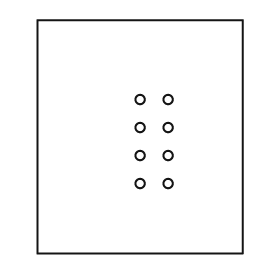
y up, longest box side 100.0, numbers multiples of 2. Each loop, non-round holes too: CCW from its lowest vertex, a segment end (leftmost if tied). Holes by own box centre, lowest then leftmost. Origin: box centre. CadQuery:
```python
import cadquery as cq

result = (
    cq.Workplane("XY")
    .moveTo(-44.0, -50.0)
    .lineTo(44.0, -50.0)
    .lineTo(44.0, 50.0)
    .lineTo(-44.0, 50.0)
    .close()
    .moveTo(0.0, -20.0)
    .circle(2.0)
    .moveTo(12.0, -20.0)
    .circle(2.0)
    .moveTo(0.0, -8.0)
    .circle(2.0)
    .moveTo(12.0, -8.0)
    .circle(2.0)
    .moveTo(0.0, 4.0)
    .circle(2.0)
    .moveTo(12.0, 4.0)
    .circle(2.0)
    .moveTo(0.0, 16.0)
    .circle(2.0)
    .moveTo(12.0, 16.0)
    .circle(2.0)
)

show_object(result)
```